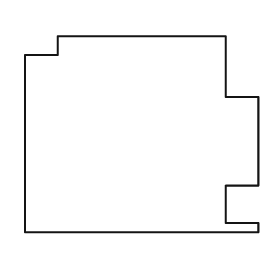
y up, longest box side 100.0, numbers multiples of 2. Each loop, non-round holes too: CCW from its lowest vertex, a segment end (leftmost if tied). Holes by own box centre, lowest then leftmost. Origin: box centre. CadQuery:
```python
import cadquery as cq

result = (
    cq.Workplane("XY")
    .moveTo(-50.0, -42.0)
    .lineTo(50.0, -42.0)
    .lineTo(50.0, -38.0)
    .lineTo(36.0, -38.0)
    .lineTo(36.0, -22.0)
    .lineTo(50.0, -22.0)
    .lineTo(50.0, 16.0)
    .lineTo(36.0, 16.0)
    .lineTo(36.0, 42.0)
    .lineTo(-36.0, 42.0)
    .lineTo(-36.0, 34.0)
    .lineTo(-50.0, 34.0)
    .close()
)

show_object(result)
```